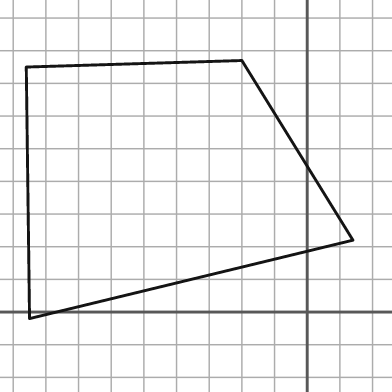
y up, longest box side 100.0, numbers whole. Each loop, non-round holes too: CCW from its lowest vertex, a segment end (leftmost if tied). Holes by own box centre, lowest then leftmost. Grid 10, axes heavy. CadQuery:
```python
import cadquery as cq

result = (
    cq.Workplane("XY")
    .moveTo(-85.0, -2.0)
    .lineTo(14.0, 22.0)
    .lineTo(-20.0, 77.0)
    .lineTo(-86.0, 75.0)
    .close()
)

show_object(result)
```